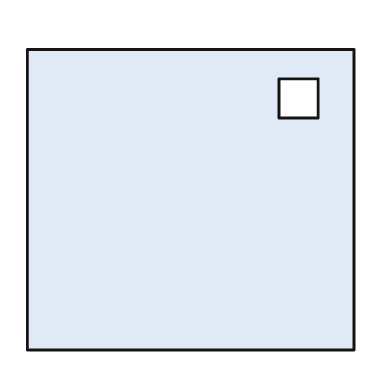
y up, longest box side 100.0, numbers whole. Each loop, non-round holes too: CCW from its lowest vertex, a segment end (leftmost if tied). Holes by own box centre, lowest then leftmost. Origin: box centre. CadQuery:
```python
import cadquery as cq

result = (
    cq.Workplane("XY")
    .moveTo(-50.0, -46.0)
    .lineTo(50.0, -46.0)
    .lineTo(50.0, 46.0)
    .lineTo(-50.0, 46.0)
    .close()
    .moveTo(27.0, 25.0)
    .lineTo(39.0, 25.0)
    .lineTo(39.0, 37.0)
    .lineTo(27.0, 37.0)
    .close()
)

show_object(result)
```